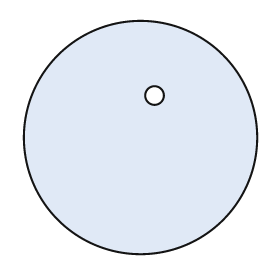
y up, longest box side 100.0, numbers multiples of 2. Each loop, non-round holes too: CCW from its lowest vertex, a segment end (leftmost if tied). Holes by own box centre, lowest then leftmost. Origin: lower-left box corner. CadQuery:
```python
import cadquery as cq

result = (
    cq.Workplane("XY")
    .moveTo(50.0, 50.0)
    .circle(50.0)
    .moveTo(56.0, 68.0)
    .circle(4.0)
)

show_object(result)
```